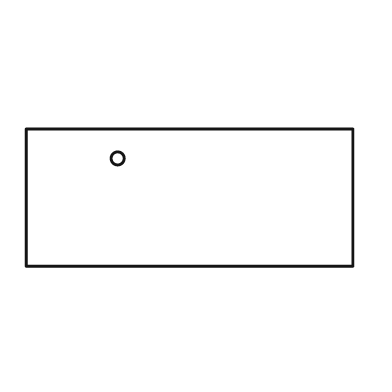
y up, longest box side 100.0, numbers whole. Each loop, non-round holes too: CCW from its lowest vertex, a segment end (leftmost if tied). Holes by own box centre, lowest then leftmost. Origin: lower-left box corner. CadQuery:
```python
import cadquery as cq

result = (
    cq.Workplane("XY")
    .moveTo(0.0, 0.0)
    .lineTo(100.0, 0.0)
    .lineTo(100.0, 42.0)
    .lineTo(0.0, 42.0)
    .close()
    .moveTo(28.0, 33.0)
    .circle(2.0)
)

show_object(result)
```